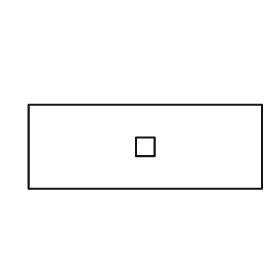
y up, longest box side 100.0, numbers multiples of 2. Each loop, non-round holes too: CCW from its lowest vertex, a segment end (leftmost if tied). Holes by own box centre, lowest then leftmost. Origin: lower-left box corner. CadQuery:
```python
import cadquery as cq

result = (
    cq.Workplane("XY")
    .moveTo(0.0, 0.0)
    .lineTo(100.0, 0.0)
    .lineTo(100.0, 36.0)
    .lineTo(0.0, 36.0)
    .close()
    .moveTo(46.0, 14.0)
    .lineTo(54.0, 14.0)
    .lineTo(54.0, 22.0)
    .lineTo(46.0, 22.0)
    .close()
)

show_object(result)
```